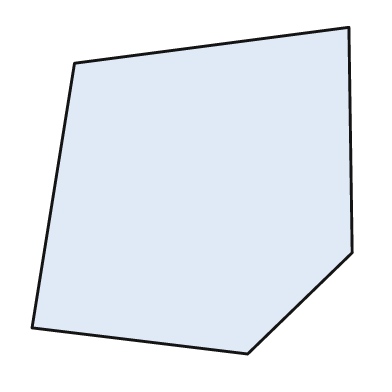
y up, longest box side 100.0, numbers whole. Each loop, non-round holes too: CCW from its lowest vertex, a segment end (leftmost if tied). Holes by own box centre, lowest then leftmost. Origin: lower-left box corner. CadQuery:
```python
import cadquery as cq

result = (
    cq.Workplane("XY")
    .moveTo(66.0, 0.0)
    .lineTo(98.0, 31.0)
    .lineTo(97.0, 100.0)
    .lineTo(13.0, 89.0)
    .lineTo(0.0, 8.0)
    .close()
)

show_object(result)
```